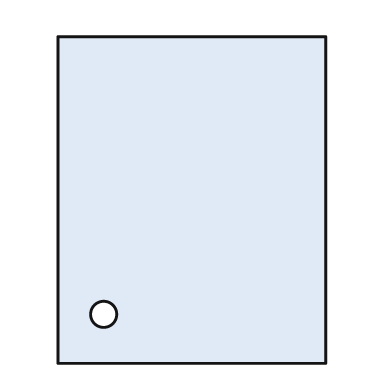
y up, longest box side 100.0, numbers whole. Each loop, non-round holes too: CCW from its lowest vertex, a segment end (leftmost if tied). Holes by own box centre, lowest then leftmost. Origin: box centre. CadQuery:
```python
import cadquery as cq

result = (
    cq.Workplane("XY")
    .moveTo(-41.0, -50.0)
    .lineTo(41.0, -50.0)
    .lineTo(41.0, 50.0)
    .lineTo(-41.0, 50.0)
    .close()
    .moveTo(-27.0, -35.0)
    .circle(4.0)
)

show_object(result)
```